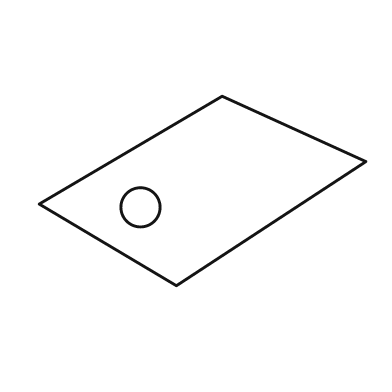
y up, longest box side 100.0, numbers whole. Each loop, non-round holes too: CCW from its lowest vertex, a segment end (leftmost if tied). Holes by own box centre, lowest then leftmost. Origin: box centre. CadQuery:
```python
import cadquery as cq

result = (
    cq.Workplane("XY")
    .moveTo(-8.0, -29.0)
    .lineTo(50.0, 9.0)
    .lineTo(6.0, 29.0)
    .lineTo(-50.0, -4.0)
    .close()
    .moveTo(-19.0, -5.0)
    .circle(6.0)
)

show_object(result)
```